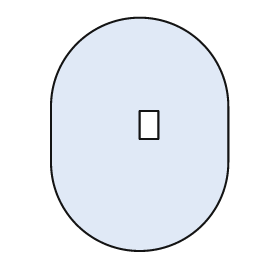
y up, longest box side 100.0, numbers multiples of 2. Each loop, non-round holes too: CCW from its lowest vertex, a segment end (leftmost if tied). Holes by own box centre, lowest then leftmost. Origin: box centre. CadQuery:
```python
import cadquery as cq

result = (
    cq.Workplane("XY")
    .moveTo(-38.0, -12.0)
    .threePointArc((0.0, -50.0), (38.0, -12.0))
    .lineTo(38.0, 12.0)
    .threePointArc((0.0, 50.0), (-38.0, 12.0))
    .close()
    .moveTo(0.0, -2.0)
    .lineTo(8.0, -2.0)
    .lineTo(8.0, 10.0)
    .lineTo(0.0, 10.0)
    .close()
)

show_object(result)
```